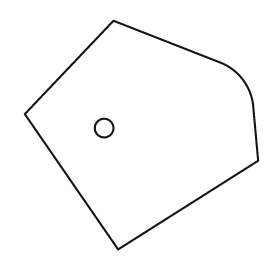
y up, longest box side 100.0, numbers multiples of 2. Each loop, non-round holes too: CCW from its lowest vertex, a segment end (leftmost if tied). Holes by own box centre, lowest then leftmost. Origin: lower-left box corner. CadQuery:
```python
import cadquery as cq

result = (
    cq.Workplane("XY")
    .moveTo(40.0, 0.0)
    .lineTo(100.0, 38.0)
    .lineTo(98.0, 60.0)
    .threePointArc((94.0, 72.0), (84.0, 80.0))
    .lineTo(38.0, 98.0)
    .lineTo(0.0, 58.0)
    .close()
    .moveTo(34.0, 52.0)
    .circle(4.0)
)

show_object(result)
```